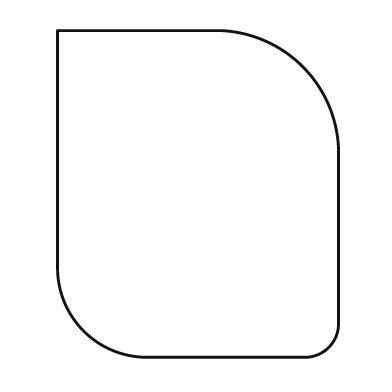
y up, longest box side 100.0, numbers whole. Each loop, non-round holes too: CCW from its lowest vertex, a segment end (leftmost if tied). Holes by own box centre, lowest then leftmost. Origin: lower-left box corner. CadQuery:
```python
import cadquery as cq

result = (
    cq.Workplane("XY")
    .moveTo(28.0, 0.0)
    .lineTo(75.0, 0.0)
    .threePointArc((83.0, 3.0), (86.0, 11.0))
    .lineTo(86.0, 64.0)
    .threePointArc((75.0, 89.0), (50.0, 100.0))
    .lineTo(0.0, 100.0)
    .lineTo(0.0, 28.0)
    .threePointArc((8.0, 8.0), (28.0, 0.0))
    .close()
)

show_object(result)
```